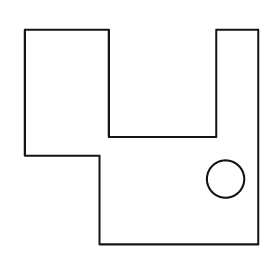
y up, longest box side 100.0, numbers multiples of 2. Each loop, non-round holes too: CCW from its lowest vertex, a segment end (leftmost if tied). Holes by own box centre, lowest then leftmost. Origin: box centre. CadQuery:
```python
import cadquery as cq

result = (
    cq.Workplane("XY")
    .moveTo(-18.0, -46.0)
    .lineTo(50.0, -46.0)
    .lineTo(50.0, 46.0)
    .lineTo(32.0, 46.0)
    .lineTo(32.0, 0.0)
    .lineTo(-14.0, 0.0)
    .lineTo(-14.0, 46.0)
    .lineTo(-50.0, 46.0)
    .lineTo(-50.0, -8.0)
    .lineTo(-18.0, -8.0)
    .close()
    .moveTo(36.0, -18.0)
    .circle(8.0)
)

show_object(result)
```